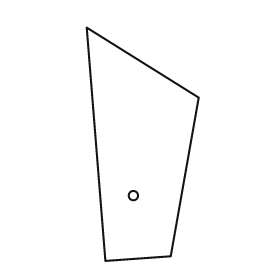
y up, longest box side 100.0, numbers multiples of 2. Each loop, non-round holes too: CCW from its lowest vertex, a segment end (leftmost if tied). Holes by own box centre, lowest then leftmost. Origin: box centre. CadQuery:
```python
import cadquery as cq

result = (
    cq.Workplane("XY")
    .moveTo(-16.0, -50.0)
    .lineTo(12.0, -48.0)
    .lineTo(24.0, 20.0)
    .lineTo(-24.0, 50.0)
    .close()
    .moveTo(-4.0, -22.0)
    .circle(2.0)
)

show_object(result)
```